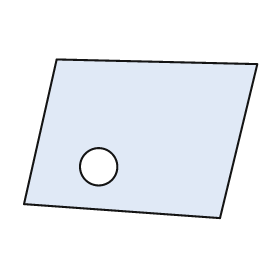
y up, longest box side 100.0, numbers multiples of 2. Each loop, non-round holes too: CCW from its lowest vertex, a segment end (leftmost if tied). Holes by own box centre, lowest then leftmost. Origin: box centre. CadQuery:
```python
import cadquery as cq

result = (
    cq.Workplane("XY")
    .moveTo(34.0, -34.0)
    .lineTo(50.0, 32.0)
    .lineTo(-36.0, 34.0)
    .lineTo(-50.0, -28.0)
    .close()
    .moveTo(-18.0, -12.0)
    .circle(8.0)
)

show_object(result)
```